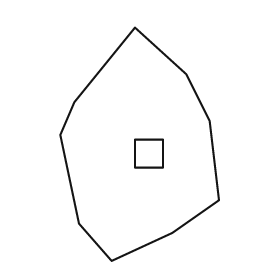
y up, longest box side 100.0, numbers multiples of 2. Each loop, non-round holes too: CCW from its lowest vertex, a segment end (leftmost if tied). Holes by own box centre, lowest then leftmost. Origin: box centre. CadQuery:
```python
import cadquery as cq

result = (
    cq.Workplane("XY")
    .moveTo(-12.0, -50.0)
    .lineTo(14.0, -38.0)
    .lineTo(34.0, -24.0)
    .lineTo(30.0, 10.0)
    .lineTo(20.0, 30.0)
    .lineTo(-2.0, 50.0)
    .lineTo(-28.0, 18.0)
    .lineTo(-34.0, 4.0)
    .lineTo(-26.0, -34.0)
    .close()
    .moveTo(-2.0, -10.0)
    .lineTo(10.0, -10.0)
    .lineTo(10.0, 2.0)
    .lineTo(-2.0, 2.0)
    .close()
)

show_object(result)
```